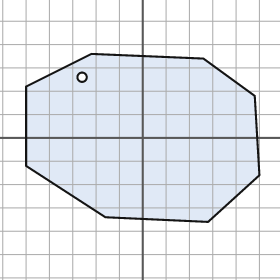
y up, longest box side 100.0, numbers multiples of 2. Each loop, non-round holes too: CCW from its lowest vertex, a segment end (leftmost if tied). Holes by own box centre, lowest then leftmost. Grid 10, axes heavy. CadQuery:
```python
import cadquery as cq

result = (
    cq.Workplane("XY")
    .moveTo(28.0, -36.0)
    .lineTo(50.0, -16.0)
    .lineTo(48.0, 18.0)
    .lineTo(26.0, 34.0)
    .lineTo(-22.0, 36.0)
    .lineTo(-50.0, 22.0)
    .lineTo(-50.0, -12.0)
    .lineTo(-16.0, -34.0)
    .close()
    .moveTo(-26.0, 26.0)
    .circle(2.0)
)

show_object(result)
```